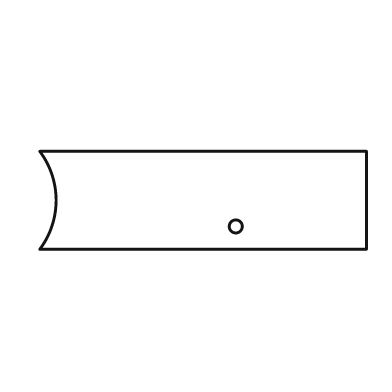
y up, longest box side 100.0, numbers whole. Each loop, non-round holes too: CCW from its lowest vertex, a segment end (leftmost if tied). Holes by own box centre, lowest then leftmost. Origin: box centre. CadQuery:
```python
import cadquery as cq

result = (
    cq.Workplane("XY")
    .moveTo(-50.0, -15.0)
    .lineTo(50.0, -15.0)
    .lineTo(50.0, 15.0)
    .lineTo(-50.0, 15.0)
    .threePointArc((-45.0, 0.0), (-50.0, -15.0))
    .close()
    .moveTo(10.0, -8.0)
    .circle(2.0)
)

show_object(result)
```